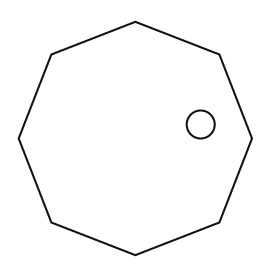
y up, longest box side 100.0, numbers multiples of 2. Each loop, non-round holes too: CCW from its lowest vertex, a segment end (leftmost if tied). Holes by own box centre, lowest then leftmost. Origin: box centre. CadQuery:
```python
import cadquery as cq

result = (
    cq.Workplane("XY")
    .moveTo(0.0, -50.0)
    .lineTo(36.0, -36.0)
    .lineTo(50.0, 0.0)
    .lineTo(36.0, 36.0)
    .lineTo(0.0, 50.0)
    .lineTo(-36.0, 36.0)
    .lineTo(-50.0, 0.0)
    .lineTo(-36.0, -36.0)
    .close()
    .moveTo(28.0, 6.0)
    .circle(6.0)
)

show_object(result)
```